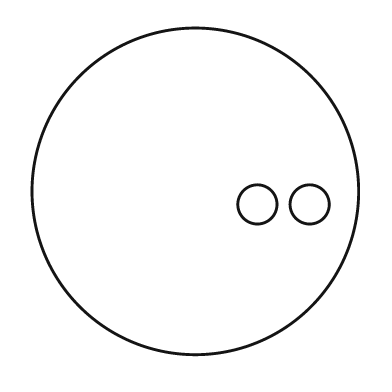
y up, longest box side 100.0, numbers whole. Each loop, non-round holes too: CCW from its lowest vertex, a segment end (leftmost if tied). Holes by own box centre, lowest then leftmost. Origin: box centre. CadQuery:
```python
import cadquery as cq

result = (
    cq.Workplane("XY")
    .moveTo(0.0, 0.0)
    .circle(50.0)
    .moveTo(19.0, -4.0)
    .circle(6.0)
    .moveTo(35.0, -4.0)
    .circle(6.0)
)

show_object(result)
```